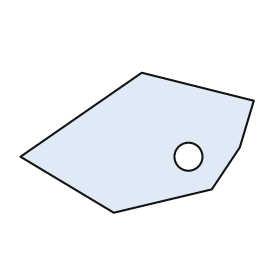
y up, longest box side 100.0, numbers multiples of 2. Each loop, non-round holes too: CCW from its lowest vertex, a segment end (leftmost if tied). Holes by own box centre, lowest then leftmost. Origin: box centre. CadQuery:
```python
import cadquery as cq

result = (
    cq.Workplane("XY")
    .moveTo(-10.0, -30.0)
    .lineTo(32.0, -20.0)
    .lineTo(44.0, -2.0)
    .lineTo(50.0, 18.0)
    .lineTo(2.0, 30.0)
    .lineTo(-50.0, -6.0)
    .close()
    .moveTo(22.0, -6.0)
    .circle(6.0)
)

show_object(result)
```